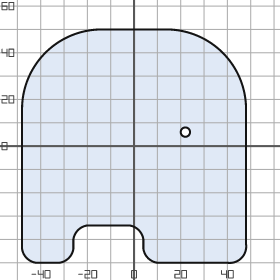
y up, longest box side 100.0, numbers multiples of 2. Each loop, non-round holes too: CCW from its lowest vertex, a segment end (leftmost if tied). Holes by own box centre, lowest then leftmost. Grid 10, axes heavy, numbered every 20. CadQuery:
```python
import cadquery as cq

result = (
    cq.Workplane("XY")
    .moveTo(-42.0, -50.0)
    .lineTo(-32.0, -50.0)
    .threePointArc((-28.0, -48.0), (-26.0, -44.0))
    .lineTo(-26.0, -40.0)
    .threePointArc((-24.0, -36.0), (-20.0, -34.0))
    .lineTo(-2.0, -34.0)
    .threePointArc((2.0, -36.0), (4.0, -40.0))
    .lineTo(4.0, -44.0)
    .threePointArc((6.0, -48.0), (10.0, -50.0))
    .lineTo(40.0, -50.0)
    .threePointArc((46.0, -48.0), (48.0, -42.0))
    .lineTo(48.0, 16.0)
    .threePointArc((38.0, 40.0), (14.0, 50.0))
    .lineTo(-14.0, 50.0)
    .threePointArc((-38.0, 40.0), (-48.0, 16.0))
    .lineTo(-48.0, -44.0)
    .threePointArc((-46.0, -48.0), (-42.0, -50.0))
    .close()
    .moveTo(22.0, 6.0)
    .circle(2.0)
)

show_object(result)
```